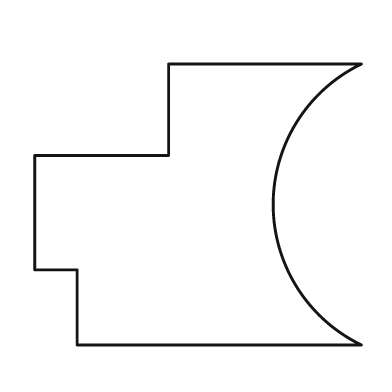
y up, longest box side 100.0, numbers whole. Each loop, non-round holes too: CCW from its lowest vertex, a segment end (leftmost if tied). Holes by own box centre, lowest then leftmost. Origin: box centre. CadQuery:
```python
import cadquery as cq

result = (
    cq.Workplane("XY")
    .moveTo(-37.0, -43.0)
    .lineTo(50.0, -43.0)
    .threePointArc((23.0, 0.0), (50.0, 43.0))
    .lineTo(-9.0, 43.0)
    .lineTo(-9.0, 15.0)
    .lineTo(-50.0, 15.0)
    .lineTo(-50.0, -20.0)
    .lineTo(-37.0, -20.0)
    .close()
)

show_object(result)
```